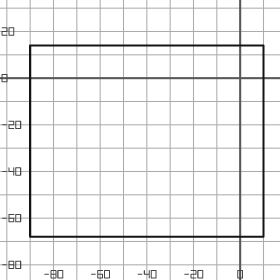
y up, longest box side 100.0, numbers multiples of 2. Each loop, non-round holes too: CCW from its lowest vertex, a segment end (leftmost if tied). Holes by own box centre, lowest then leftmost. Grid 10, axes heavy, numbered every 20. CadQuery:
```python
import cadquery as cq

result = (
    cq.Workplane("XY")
    .moveTo(-90.0, -68.0)
    .lineTo(10.0, -68.0)
    .lineTo(10.0, 14.0)
    .lineTo(-90.0, 14.0)
    .close()
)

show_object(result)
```